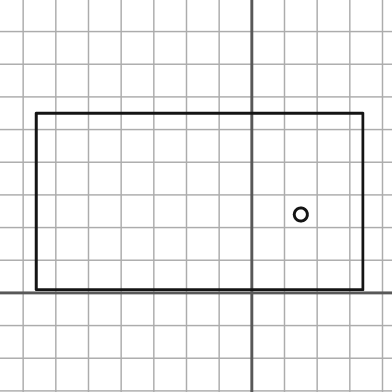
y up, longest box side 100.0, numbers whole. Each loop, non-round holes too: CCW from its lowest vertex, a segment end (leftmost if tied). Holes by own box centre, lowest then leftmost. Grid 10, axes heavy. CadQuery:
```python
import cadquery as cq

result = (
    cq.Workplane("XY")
    .moveTo(-66.0, 1.0)
    .lineTo(34.0, 1.0)
    .lineTo(34.0, 55.0)
    .lineTo(-66.0, 55.0)
    .close()
    .moveTo(15.0, 24.0)
    .circle(2.0)
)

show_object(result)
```